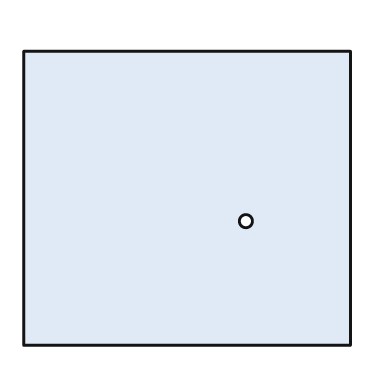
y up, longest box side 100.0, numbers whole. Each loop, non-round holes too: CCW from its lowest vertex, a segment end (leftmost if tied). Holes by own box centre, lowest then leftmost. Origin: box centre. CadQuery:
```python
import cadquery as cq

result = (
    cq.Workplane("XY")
    .moveTo(-50.0, -45.0)
    .lineTo(50.0, -45.0)
    .lineTo(50.0, 45.0)
    .lineTo(-50.0, 45.0)
    .close()
    .moveTo(18.0, -7.0)
    .circle(2.0)
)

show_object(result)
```